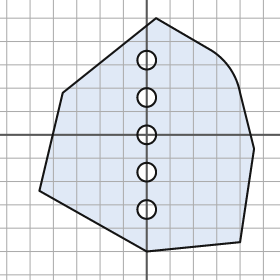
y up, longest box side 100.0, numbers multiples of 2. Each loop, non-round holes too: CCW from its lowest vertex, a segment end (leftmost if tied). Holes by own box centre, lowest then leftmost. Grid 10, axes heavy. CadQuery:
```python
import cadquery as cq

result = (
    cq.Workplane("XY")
    .moveTo(0.0, -50.0)
    .lineTo(40.0, -46.0)
    .lineTo(46.0, -6.0)
    .lineTo(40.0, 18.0)
    .threePointArc((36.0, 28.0), (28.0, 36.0))
    .lineTo(4.0, 50.0)
    .lineTo(-36.0, 18.0)
    .lineTo(-46.0, -24.0)
    .close()
    .moveTo(0.0, -32.0)
    .circle(4.0)
    .moveTo(0.0, -16.0)
    .circle(4.0)
    .moveTo(0.0, 0.0)
    .circle(4.0)
    .moveTo(0.0, 16.0)
    .circle(4.0)
    .moveTo(0.0, 32.0)
    .circle(4.0)
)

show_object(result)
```